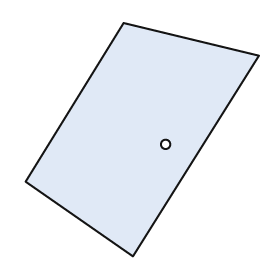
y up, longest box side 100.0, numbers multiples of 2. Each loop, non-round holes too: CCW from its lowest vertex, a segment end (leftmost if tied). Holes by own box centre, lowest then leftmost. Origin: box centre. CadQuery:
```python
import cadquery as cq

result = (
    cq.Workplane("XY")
    .moveTo(-4.0, -50.0)
    .lineTo(50.0, 36.0)
    .lineTo(-8.0, 50.0)
    .lineTo(-50.0, -18.0)
    .close()
    .moveTo(10.0, -2.0)
    .circle(2.0)
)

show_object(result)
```